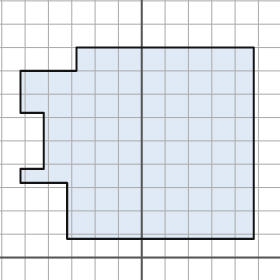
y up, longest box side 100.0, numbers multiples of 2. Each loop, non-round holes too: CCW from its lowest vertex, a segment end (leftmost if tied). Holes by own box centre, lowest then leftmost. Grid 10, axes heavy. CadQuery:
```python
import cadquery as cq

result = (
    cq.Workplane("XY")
    .moveTo(-32.0, 8.0)
    .lineTo(48.0, 8.0)
    .lineTo(48.0, 90.0)
    .lineTo(-28.0, 90.0)
    .lineTo(-28.0, 80.0)
    .lineTo(-52.0, 80.0)
    .lineTo(-52.0, 62.0)
    .lineTo(-42.0, 62.0)
    .lineTo(-42.0, 38.0)
    .lineTo(-52.0, 38.0)
    .lineTo(-52.0, 32.0)
    .lineTo(-32.0, 32.0)
    .close()
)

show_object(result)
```